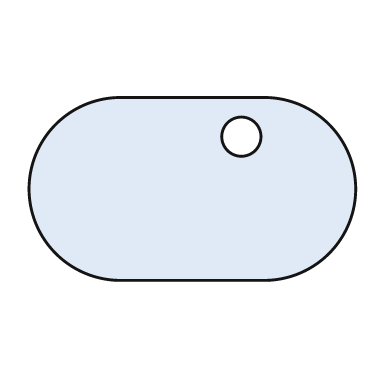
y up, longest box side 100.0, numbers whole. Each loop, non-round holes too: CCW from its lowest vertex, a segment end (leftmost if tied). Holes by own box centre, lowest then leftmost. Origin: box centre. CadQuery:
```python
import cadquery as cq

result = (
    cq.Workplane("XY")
    .moveTo(-22.0, -28.0)
    .lineTo(22.0, -28.0)
    .threePointArc((50.0, 0.0), (22.0, 28.0))
    .lineTo(-22.0, 28.0)
    .threePointArc((-50.0, 0.0), (-22.0, -28.0))
    .close()
    .moveTo(15.0, 16.0)
    .circle(6.0)
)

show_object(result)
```